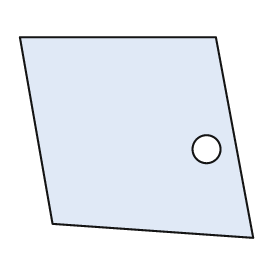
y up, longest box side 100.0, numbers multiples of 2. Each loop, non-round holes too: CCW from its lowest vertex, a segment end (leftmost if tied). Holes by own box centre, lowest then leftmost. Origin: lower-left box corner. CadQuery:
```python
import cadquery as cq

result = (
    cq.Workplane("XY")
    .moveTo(100.0, 0.0)
    .lineTo(84.0, 86.0)
    .lineTo(0.0, 86.0)
    .lineTo(14.0, 6.0)
    .close()
    .moveTo(80.0, 38.0)
    .circle(6.0)
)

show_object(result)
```